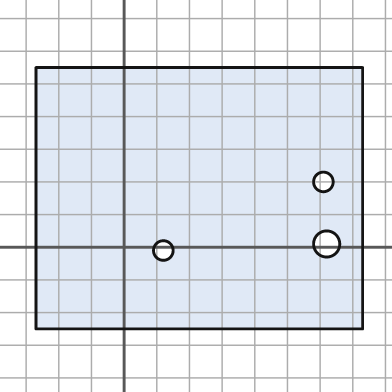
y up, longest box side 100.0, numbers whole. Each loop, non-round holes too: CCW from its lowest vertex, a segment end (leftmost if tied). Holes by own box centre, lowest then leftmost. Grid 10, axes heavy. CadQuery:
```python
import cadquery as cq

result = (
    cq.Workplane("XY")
    .moveTo(-27.0, -25.0)
    .lineTo(73.0, -25.0)
    .lineTo(73.0, 55.0)
    .lineTo(-27.0, 55.0)
    .close()
    .moveTo(12.0, -1.0)
    .circle(3.0)
    .moveTo(62.0, 1.0)
    .circle(4.0)
    .moveTo(61.0, 20.0)
    .circle(3.0)
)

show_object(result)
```